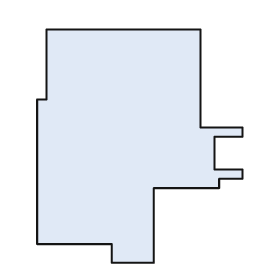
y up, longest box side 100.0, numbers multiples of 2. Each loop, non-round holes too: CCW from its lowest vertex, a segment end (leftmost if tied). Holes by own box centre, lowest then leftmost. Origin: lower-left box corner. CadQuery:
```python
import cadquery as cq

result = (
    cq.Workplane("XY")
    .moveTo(32.0, 0.0)
    .lineTo(50.0, 0.0)
    .lineTo(50.0, 32.0)
    .lineTo(78.0, 32.0)
    .lineTo(78.0, 36.0)
    .lineTo(88.0, 36.0)
    .lineTo(88.0, 40.0)
    .lineTo(76.0, 40.0)
    .lineTo(76.0, 54.0)
    .lineTo(88.0, 54.0)
    .lineTo(88.0, 58.0)
    .lineTo(70.0, 58.0)
    .lineTo(70.0, 100.0)
    .lineTo(4.0, 100.0)
    .lineTo(4.0, 70.0)
    .lineTo(0.0, 70.0)
    .lineTo(0.0, 8.0)
    .lineTo(32.0, 8.0)
    .close()
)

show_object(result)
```